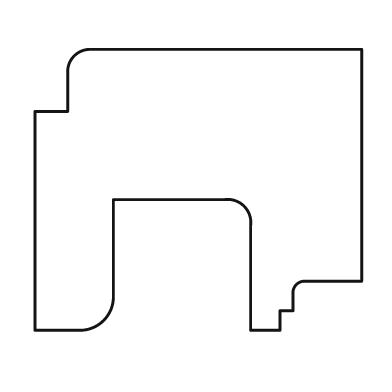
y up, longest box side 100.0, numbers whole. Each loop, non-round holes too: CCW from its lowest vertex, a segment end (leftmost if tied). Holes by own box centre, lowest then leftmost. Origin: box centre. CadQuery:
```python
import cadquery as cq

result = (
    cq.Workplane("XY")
    .moveTo(-50.0, -43.0)
    .lineTo(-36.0, -43.0)
    .threePointArc((-29.0, -40.0), (-26.0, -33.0))
    .lineTo(-26.0, -3.0)
    .lineTo(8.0, -3.0)
    .threePointArc((14.0, -5.0), (16.0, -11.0))
    .lineTo(16.0, -43.0)
    .lineTo(25.0, -43.0)
    .lineTo(25.0, -37.0)
    .lineTo(29.0, -37.0)
    .lineTo(29.0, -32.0)
    .threePointArc((30.0, -29.0), (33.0, -28.0))
    .lineTo(50.0, -28.0)
    .lineTo(50.0, 43.0)
    .lineTo(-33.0, 43.0)
    .threePointArc((-38.0, 41.0), (-40.0, 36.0))
    .lineTo(-40.0, 24.0)
    .lineTo(-50.0, 24.0)
    .close()
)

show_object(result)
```